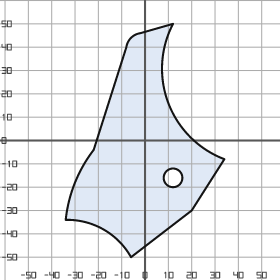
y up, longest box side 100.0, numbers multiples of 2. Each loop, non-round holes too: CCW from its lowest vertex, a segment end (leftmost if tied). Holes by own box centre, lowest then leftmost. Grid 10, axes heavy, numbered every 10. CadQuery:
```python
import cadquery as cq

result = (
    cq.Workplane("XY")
    .moveTo(-6.0, -50.0)
    .lineTo(20.0, -30.0)
    .lineTo(34.0, -8.0)
    .threePointArc((10.0, 16.0), (12.0, 50.0))
    .lineTo(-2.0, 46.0)
    .threePointArc((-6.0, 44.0), (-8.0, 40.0))
    .lineTo(-22.0, -4.0)
    .threePointArc((-30.0, -18.0), (-34.0, -34.0))
    .threePointArc((-18.0, -38.0), (-6.0, -50.0))
    .close()
    .moveTo(12.0, -16.0)
    .circle(4.0)
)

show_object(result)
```